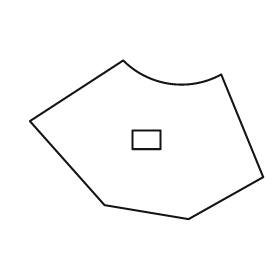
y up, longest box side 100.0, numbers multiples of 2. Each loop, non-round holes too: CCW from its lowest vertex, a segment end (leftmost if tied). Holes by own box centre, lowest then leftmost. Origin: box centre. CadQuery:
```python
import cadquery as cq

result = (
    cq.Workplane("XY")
    .moveTo(18.0, -34.0)
    .lineTo(50.0, -16.0)
    .lineTo(32.0, 28.0)
    .threePointArc((10.0, 24.0), (-10.0, 34.0))
    .lineTo(-50.0, 8.0)
    .lineTo(-18.0, -28.0)
    .close()
    .moveTo(-6.0, -4.0)
    .lineTo(6.0, -4.0)
    .lineTo(6.0, 4.0)
    .lineTo(-6.0, 4.0)
    .close()
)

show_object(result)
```